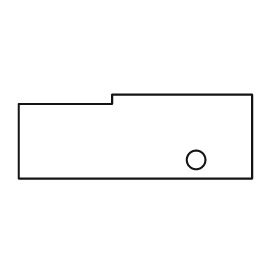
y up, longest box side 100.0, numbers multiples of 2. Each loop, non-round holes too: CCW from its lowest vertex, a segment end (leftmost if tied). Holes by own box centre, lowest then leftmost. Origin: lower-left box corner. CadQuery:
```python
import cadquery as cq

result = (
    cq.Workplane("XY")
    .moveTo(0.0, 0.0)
    .lineTo(100.0, 0.0)
    .lineTo(100.0, 36.0)
    .lineTo(40.0, 36.0)
    .lineTo(40.0, 32.0)
    .lineTo(0.0, 32.0)
    .close()
    .moveTo(76.0, 8.0)
    .circle(4.0)
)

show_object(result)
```